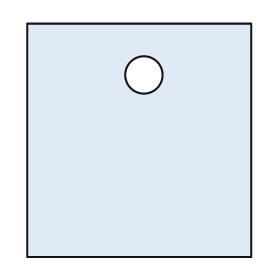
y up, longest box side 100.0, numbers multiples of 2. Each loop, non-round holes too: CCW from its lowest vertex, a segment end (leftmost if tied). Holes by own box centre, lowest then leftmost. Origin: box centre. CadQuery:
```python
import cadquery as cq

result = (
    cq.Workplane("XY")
    .moveTo(-48.0, -50.0)
    .lineTo(48.0, -50.0)
    .lineTo(48.0, 50.0)
    .lineTo(-48.0, 50.0)
    .close()
    .moveTo(2.0, 28.0)
    .circle(8.0)
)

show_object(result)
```